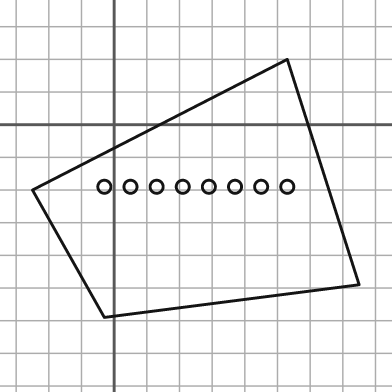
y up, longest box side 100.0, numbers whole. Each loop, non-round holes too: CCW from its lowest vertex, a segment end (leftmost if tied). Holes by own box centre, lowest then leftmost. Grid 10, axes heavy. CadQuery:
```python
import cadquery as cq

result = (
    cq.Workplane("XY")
    .moveTo(-3.0, -59.0)
    .lineTo(75.0, -49.0)
    .lineTo(53.0, 20.0)
    .lineTo(-25.0, -20.0)
    .close()
    .moveTo(-3.0, -19.0)
    .circle(2.0)
    .moveTo(5.0, -19.0)
    .circle(2.0)
    .moveTo(13.0, -19.0)
    .circle(2.0)
    .moveTo(21.0, -19.0)
    .circle(2.0)
    .moveTo(29.0, -19.0)
    .circle(2.0)
    .moveTo(37.0, -19.0)
    .circle(2.0)
    .moveTo(45.0, -19.0)
    .circle(2.0)
    .moveTo(53.0, -19.0)
    .circle(2.0)
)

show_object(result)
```